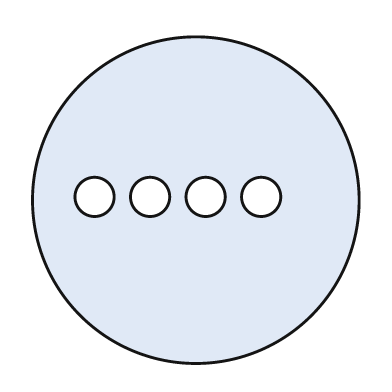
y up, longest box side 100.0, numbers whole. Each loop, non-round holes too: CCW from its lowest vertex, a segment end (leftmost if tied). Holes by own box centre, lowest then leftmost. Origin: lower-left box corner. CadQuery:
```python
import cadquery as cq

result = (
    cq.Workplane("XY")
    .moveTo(50.0, 50.0)
    .circle(50.0)
    .moveTo(19.0, 51.0)
    .circle(6.0)
    .moveTo(36.0, 51.0)
    .circle(6.0)
    .moveTo(53.0, 51.0)
    .circle(6.0)
    .moveTo(70.0, 51.0)
    .circle(6.0)
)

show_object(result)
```